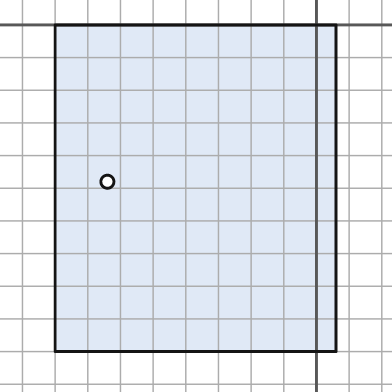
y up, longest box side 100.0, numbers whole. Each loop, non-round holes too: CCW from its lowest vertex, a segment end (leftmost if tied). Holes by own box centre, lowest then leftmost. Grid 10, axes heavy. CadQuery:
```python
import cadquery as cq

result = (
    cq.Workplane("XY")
    .moveTo(-80.0, -100.0)
    .lineTo(6.0, -100.0)
    .lineTo(6.0, 0.0)
    .lineTo(-80.0, 0.0)
    .close()
    .moveTo(-64.0, -48.0)
    .circle(2.0)
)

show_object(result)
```